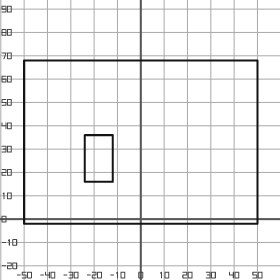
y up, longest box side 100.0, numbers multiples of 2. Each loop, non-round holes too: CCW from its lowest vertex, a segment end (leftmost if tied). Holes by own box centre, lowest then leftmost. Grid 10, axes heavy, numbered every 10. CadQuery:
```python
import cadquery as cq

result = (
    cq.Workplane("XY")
    .moveTo(-50.0, -2.0)
    .lineTo(50.0, -2.0)
    .lineTo(50.0, 68.0)
    .lineTo(-50.0, 68.0)
    .close()
    .moveTo(-24.0, 16.0)
    .lineTo(-12.0, 16.0)
    .lineTo(-12.0, 36.0)
    .lineTo(-24.0, 36.0)
    .close()
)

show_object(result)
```